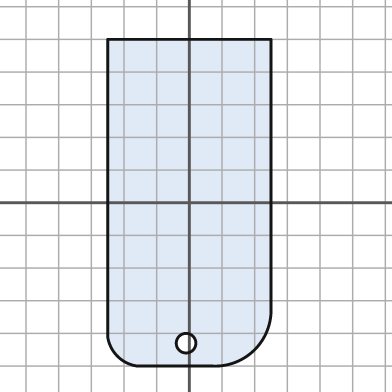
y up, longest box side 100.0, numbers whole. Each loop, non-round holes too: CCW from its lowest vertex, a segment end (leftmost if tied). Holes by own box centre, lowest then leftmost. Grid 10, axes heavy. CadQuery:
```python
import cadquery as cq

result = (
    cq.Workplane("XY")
    .moveTo(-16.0, -50.0)
    .lineTo(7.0, -50.0)
    .threePointArc((20.0, -45.0), (25.0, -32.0))
    .lineTo(25.0, 50.0)
    .lineTo(-25.0, 50.0)
    .lineTo(-25.0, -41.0)
    .threePointArc((-22.0, -47.0), (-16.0, -50.0))
    .close()
    .moveTo(-1.0, -43.0)
    .circle(3.0)
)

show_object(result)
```